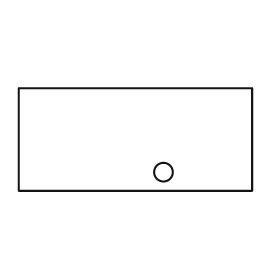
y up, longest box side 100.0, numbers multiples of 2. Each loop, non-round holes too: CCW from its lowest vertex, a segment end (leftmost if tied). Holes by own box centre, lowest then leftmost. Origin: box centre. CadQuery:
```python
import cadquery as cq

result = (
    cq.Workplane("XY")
    .moveTo(-50.0, -22.0)
    .lineTo(50.0, -22.0)
    .lineTo(50.0, 22.0)
    .lineTo(-50.0, 22.0)
    .close()
    .moveTo(12.0, -14.0)
    .circle(4.0)
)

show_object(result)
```